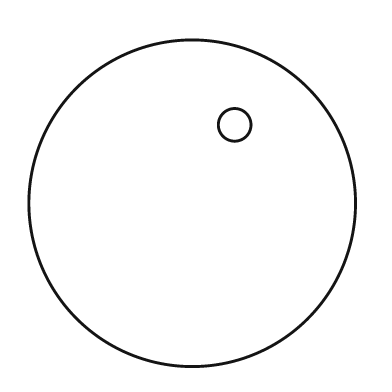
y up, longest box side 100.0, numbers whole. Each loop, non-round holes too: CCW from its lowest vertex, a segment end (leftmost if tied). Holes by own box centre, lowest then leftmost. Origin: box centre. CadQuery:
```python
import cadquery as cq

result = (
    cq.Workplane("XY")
    .moveTo(0.0, 0.0)
    .circle(50.0)
    .moveTo(13.0, 24.0)
    .circle(5.0)
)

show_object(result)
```